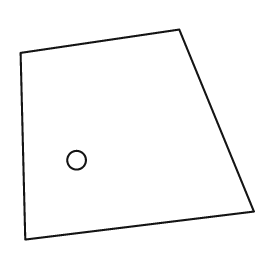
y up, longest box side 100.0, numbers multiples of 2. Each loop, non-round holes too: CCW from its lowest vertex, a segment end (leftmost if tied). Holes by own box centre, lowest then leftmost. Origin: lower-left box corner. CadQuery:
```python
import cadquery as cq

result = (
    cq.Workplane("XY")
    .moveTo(2.0, 0.0)
    .lineTo(100.0, 12.0)
    .lineTo(68.0, 90.0)
    .lineTo(0.0, 80.0)
    .close()
    .moveTo(24.0, 34.0)
    .circle(4.0)
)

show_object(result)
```